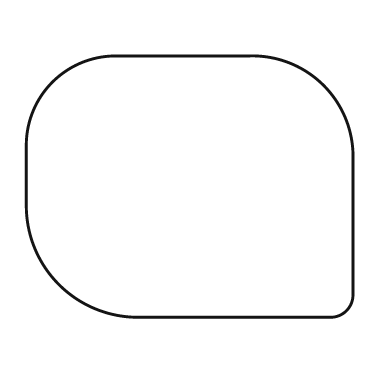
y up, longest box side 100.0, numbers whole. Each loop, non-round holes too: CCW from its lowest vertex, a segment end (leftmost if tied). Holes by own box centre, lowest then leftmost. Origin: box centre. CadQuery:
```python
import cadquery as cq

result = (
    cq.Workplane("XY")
    .moveTo(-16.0, -40.0)
    .lineTo(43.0, -40.0)
    .threePointArc((48.0, -38.0), (50.0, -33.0))
    .lineTo(50.0, 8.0)
    .threePointArc((41.0, 31.0), (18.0, 40.0))
    .lineTo(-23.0, 40.0)
    .threePointArc((-42.0, 32.0), (-50.0, 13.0))
    .lineTo(-50.0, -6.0)
    .threePointArc((-40.0, -30.0), (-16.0, -40.0))
    .close()
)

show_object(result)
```